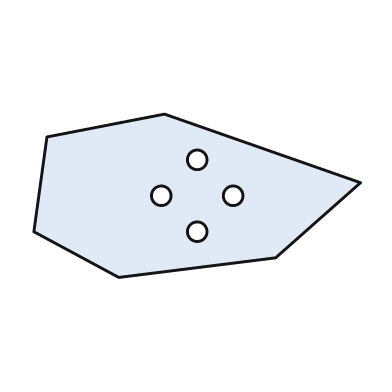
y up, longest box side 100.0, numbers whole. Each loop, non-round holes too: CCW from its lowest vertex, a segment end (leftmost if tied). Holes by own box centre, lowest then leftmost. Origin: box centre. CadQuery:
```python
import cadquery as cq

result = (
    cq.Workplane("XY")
    .moveTo(-24.0, -25.0)
    .lineTo(24.0, -19.0)
    .lineTo(50.0, 4.0)
    .lineTo(-10.0, 25.0)
    .lineTo(-46.0, 18.0)
    .lineTo(-50.0, -11.0)
    .close()
    .moveTo(0.0, -11.0)
    .circle(3.0)
    .moveTo(-11.0, 0.0)
    .circle(3.0)
    .moveTo(11.0, 0.0)
    .circle(3.0)
    .moveTo(0.0, 11.0)
    .circle(3.0)
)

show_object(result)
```